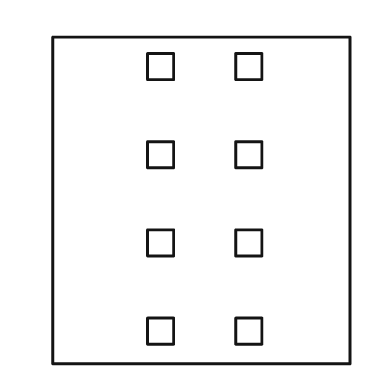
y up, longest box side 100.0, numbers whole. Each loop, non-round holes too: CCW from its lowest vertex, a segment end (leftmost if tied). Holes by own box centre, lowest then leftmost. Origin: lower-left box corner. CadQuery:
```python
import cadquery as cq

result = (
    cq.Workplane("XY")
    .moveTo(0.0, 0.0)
    .lineTo(91.0, 0.0)
    .lineTo(91.0, 100.0)
    .lineTo(0.0, 100.0)
    .close()
    .moveTo(29.0, 6.0)
    .lineTo(37.0, 6.0)
    .lineTo(37.0, 14.0)
    .lineTo(29.0, 14.0)
    .close()
    .moveTo(56.0, 6.0)
    .lineTo(64.0, 6.0)
    .lineTo(64.0, 14.0)
    .lineTo(56.0, 14.0)
    .close()
    .moveTo(29.0, 33.0)
    .lineTo(37.0, 33.0)
    .lineTo(37.0, 41.0)
    .lineTo(29.0, 41.0)
    .close()
    .moveTo(56.0, 33.0)
    .lineTo(64.0, 33.0)
    .lineTo(64.0, 41.0)
    .lineTo(56.0, 41.0)
    .close()
    .moveTo(29.0, 60.0)
    .lineTo(37.0, 60.0)
    .lineTo(37.0, 68.0)
    .lineTo(29.0, 68.0)
    .close()
    .moveTo(56.0, 60.0)
    .lineTo(64.0, 60.0)
    .lineTo(64.0, 68.0)
    .lineTo(56.0, 68.0)
    .close()
    .moveTo(29.0, 87.0)
    .lineTo(37.0, 87.0)
    .lineTo(37.0, 95.0)
    .lineTo(29.0, 95.0)
    .close()
    .moveTo(56.0, 87.0)
    .lineTo(64.0, 87.0)
    .lineTo(64.0, 95.0)
    .lineTo(56.0, 95.0)
    .close()
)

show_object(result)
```